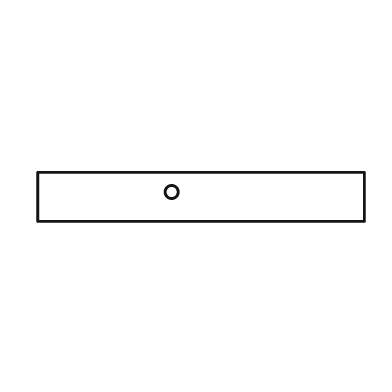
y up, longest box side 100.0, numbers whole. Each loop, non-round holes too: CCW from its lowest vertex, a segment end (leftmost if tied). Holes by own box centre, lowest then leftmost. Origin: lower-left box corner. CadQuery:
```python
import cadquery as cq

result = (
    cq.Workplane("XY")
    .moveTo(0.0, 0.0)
    .lineTo(100.0, 0.0)
    .lineTo(100.0, 15.0)
    .lineTo(0.0, 15.0)
    .close()
    .moveTo(41.0, 9.0)
    .circle(2.0)
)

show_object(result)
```